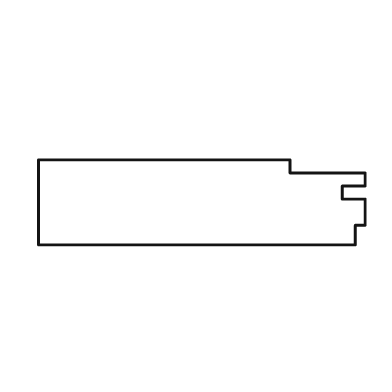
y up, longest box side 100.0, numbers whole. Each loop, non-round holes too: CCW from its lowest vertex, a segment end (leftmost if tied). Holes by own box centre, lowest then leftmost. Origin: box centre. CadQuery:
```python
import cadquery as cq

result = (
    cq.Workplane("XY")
    .moveTo(-50.0, -13.0)
    .lineTo(47.0, -13.0)
    .lineTo(47.0, -7.0)
    .lineTo(50.0, -7.0)
    .lineTo(50.0, 1.0)
    .lineTo(43.0, 1.0)
    .lineTo(43.0, 5.0)
    .lineTo(50.0, 5.0)
    .lineTo(50.0, 9.0)
    .lineTo(27.0, 9.0)
    .lineTo(27.0, 13.0)
    .lineTo(-50.0, 13.0)
    .close()
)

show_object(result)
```